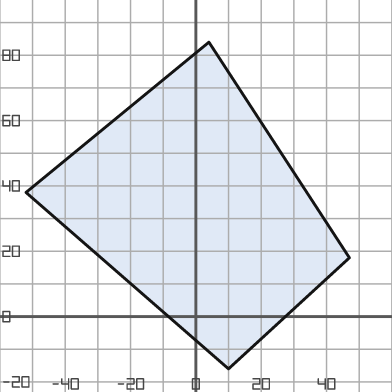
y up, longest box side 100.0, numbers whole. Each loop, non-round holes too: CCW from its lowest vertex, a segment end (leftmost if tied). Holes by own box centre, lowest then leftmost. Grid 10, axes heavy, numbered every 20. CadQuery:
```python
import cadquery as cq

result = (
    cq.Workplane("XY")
    .moveTo(10.0, -16.0)
    .lineTo(47.0, 18.0)
    .lineTo(4.0, 84.0)
    .lineTo(-52.0, 38.0)
    .close()
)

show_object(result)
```